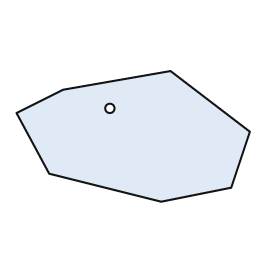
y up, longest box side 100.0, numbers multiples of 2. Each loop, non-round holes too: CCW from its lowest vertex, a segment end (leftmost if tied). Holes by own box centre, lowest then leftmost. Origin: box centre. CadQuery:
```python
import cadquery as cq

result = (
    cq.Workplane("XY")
    .moveTo(12.0, -28.0)
    .lineTo(42.0, -22.0)
    .lineTo(50.0, 2.0)
    .lineTo(16.0, 28.0)
    .lineTo(-30.0, 20.0)
    .lineTo(-50.0, 10.0)
    .lineTo(-36.0, -16.0)
    .close()
    .moveTo(-10.0, 12.0)
    .circle(2.0)
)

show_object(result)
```